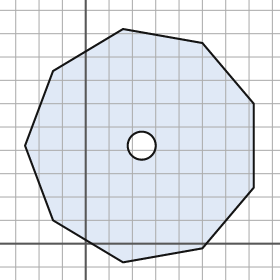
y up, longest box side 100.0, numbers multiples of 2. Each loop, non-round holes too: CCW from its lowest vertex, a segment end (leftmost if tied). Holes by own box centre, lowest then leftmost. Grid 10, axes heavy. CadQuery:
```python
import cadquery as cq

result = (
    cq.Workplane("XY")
    .moveTo(16.0, -8.0)
    .lineTo(50.0, -2.0)
    .lineTo(72.0, 24.0)
    .lineTo(72.0, 60.0)
    .lineTo(50.0, 86.0)
    .lineTo(16.0, 92.0)
    .lineTo(-14.0, 74.0)
    .lineTo(-26.0, 42.0)
    .lineTo(-14.0, 10.0)
    .close()
    .moveTo(24.0, 42.0)
    .circle(6.0)
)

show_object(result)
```